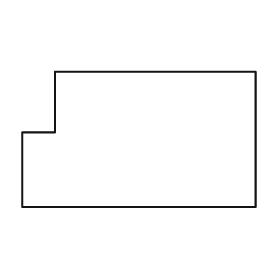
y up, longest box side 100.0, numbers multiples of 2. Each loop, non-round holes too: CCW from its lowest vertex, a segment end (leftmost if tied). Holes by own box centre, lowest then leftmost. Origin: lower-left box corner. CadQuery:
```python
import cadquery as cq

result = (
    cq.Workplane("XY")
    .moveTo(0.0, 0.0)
    .lineTo(100.0, 0.0)
    .lineTo(100.0, 58.0)
    .lineTo(14.0, 58.0)
    .lineTo(14.0, 32.0)
    .lineTo(0.0, 32.0)
    .close()
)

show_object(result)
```